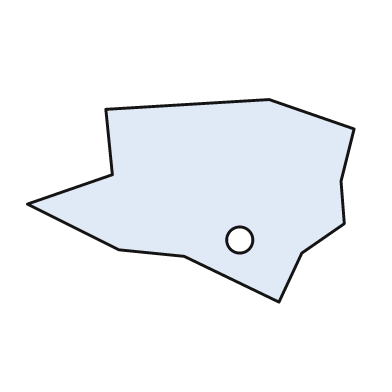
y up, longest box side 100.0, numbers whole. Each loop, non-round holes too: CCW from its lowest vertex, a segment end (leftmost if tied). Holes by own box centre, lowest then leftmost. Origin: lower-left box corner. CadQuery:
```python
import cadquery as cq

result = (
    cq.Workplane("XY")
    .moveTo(77.0, 0.0)
    .lineTo(84.0, 15.0)
    .lineTo(97.0, 24.0)
    .lineTo(96.0, 37.0)
    .lineTo(100.0, 53.0)
    .lineTo(74.0, 62.0)
    .lineTo(24.0, 59.0)
    .lineTo(26.0, 39.0)
    .lineTo(0.0, 30.0)
    .lineTo(28.0, 16.0)
    .lineTo(48.0, 14.0)
    .close()
    .moveTo(65.0, 19.0)
    .circle(4.0)
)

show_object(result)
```